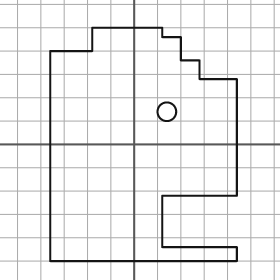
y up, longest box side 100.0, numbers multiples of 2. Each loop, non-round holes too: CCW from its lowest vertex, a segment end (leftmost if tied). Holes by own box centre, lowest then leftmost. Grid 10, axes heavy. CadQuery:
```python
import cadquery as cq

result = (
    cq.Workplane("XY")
    .moveTo(-36.0, -50.0)
    .lineTo(44.0, -50.0)
    .lineTo(44.0, -44.0)
    .lineTo(12.0, -44.0)
    .lineTo(12.0, -22.0)
    .lineTo(44.0, -22.0)
    .lineTo(44.0, 28.0)
    .lineTo(28.0, 28.0)
    .lineTo(28.0, 36.0)
    .lineTo(20.0, 36.0)
    .lineTo(20.0, 46.0)
    .lineTo(12.0, 46.0)
    .lineTo(12.0, 50.0)
    .lineTo(-18.0, 50.0)
    .lineTo(-18.0, 40.0)
    .lineTo(-36.0, 40.0)
    .close()
    .moveTo(14.0, 14.0)
    .circle(4.0)
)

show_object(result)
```